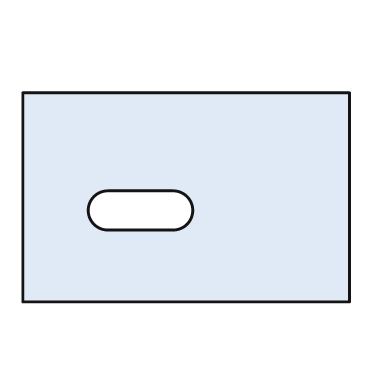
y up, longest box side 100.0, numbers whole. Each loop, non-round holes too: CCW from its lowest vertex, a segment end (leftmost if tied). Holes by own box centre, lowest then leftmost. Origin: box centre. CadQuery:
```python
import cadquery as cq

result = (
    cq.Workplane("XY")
    .moveTo(-50.0, -32.0)
    .lineTo(50.0, -32.0)
    .lineTo(50.0, 32.0)
    .lineTo(-50.0, 32.0)
    .close()
    .moveTo(-24.0, -10.0)
    .lineTo(-4.0, -10.0)
    .threePointArc((2.0, -4.0), (-4.0, 2.0))
    .lineTo(-24.0, 2.0)
    .threePointArc((-30.0, -4.0), (-24.0, -10.0))
    .close()
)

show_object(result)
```